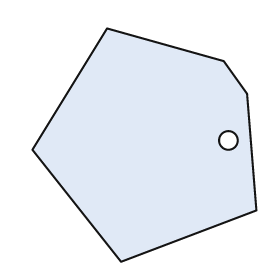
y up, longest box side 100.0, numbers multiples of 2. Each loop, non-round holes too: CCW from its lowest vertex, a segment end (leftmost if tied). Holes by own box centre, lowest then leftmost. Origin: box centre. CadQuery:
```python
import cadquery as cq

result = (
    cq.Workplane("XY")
    .moveTo(-10.0, -50.0)
    .lineTo(48.0, -28.0)
    .lineTo(44.0, 22.0)
    .lineTo(34.0, 36.0)
    .lineTo(-16.0, 50.0)
    .lineTo(-48.0, -2.0)
    .close()
    .moveTo(36.0, 2.0)
    .circle(4.0)
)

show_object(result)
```